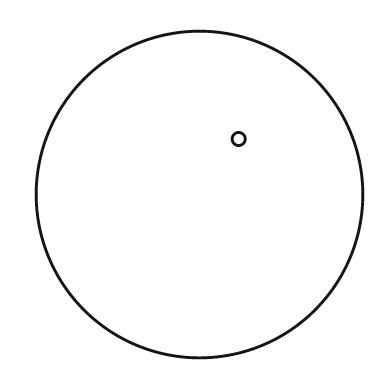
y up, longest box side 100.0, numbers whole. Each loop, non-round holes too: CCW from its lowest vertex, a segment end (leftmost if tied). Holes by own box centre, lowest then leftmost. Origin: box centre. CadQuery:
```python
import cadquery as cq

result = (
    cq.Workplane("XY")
    .moveTo(0.0, 0.0)
    .circle(50.0)
    .moveTo(12.0, 17.0)
    .circle(2.0)
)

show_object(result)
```